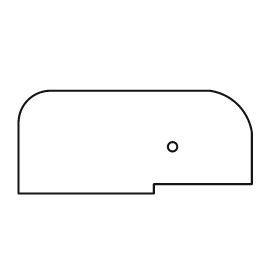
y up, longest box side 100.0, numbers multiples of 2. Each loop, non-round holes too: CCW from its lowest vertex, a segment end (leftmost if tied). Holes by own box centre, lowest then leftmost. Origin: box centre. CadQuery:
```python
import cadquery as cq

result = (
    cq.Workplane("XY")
    .moveTo(-50.0, -22.0)
    .lineTo(8.0, -22.0)
    .lineTo(8.0, -18.0)
    .lineTo(50.0, -18.0)
    .lineTo(50.0, 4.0)
    .threePointArc((44.0, 16.0), (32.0, 22.0))
    .lineTo(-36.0, 22.0)
    .threePointArc((-46.0, 18.0), (-50.0, 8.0))
    .close()
    .moveTo(16.0, -2.0)
    .circle(2.0)
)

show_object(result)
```